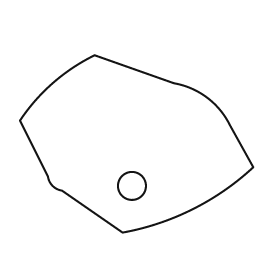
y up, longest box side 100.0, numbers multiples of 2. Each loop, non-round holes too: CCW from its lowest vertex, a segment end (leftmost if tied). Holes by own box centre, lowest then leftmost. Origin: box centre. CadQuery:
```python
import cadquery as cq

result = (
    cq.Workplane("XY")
    .moveTo(-6.0, -38.0)
    .threePointArc((24.0, -28.0), (50.0, -10.0))
    .lineTo(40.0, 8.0)
    .threePointArc((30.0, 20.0), (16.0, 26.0))
    .lineTo(-18.0, 38.0)
    .threePointArc((-36.0, 26.0), (-50.0, 10.0))
    .lineTo(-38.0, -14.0)
    .threePointArc((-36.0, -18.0), (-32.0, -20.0))
    .close()
    .moveTo(-2.0, -18.0)
    .circle(6.0)
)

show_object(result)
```